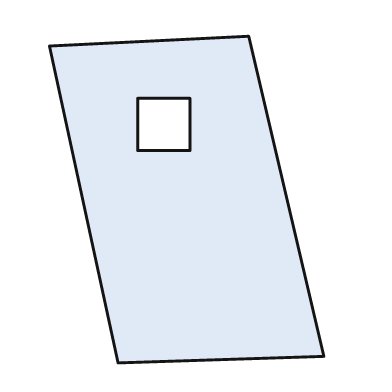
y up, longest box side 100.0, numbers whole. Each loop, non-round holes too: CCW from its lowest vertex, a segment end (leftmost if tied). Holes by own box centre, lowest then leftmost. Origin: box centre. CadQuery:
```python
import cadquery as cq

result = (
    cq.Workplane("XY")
    .moveTo(-21.0, -50.0)
    .lineTo(42.0, -48.0)
    .lineTo(19.0, 50.0)
    .lineTo(-42.0, 47.0)
    .close()
    .moveTo(-15.0, 15.0)
    .lineTo(1.0, 15.0)
    .lineTo(1.0, 31.0)
    .lineTo(-15.0, 31.0)
    .close()
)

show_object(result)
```